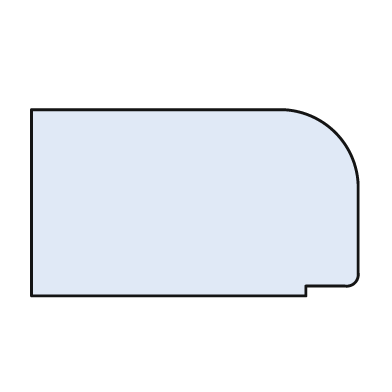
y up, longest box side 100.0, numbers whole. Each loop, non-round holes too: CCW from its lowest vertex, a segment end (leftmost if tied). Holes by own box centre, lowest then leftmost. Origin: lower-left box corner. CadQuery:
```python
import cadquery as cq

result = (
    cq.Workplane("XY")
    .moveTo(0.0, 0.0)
    .lineTo(84.0, 0.0)
    .lineTo(84.0, 3.0)
    .lineTo(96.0, 3.0)
    .threePointArc((99.0, 4.0), (100.0, 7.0))
    .lineTo(100.0, 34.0)
    .threePointArc((93.0, 50.0), (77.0, 57.0))
    .lineTo(0.0, 57.0)
    .close()
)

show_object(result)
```